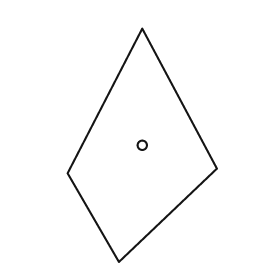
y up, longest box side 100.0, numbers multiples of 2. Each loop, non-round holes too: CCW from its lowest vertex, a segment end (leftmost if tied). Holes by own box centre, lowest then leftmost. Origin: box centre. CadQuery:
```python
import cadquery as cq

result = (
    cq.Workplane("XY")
    .moveTo(-10.0, -50.0)
    .lineTo(32.0, -10.0)
    .lineTo(0.0, 50.0)
    .lineTo(-32.0, -12.0)
    .close()
    .moveTo(0.0, 0.0)
    .circle(2.0)
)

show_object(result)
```